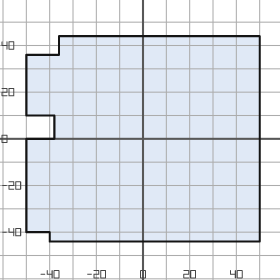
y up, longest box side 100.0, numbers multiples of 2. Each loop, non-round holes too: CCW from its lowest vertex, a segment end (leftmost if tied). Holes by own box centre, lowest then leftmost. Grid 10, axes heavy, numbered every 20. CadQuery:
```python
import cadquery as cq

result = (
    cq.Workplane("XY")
    .moveTo(-40.0, -44.0)
    .lineTo(50.0, -44.0)
    .lineTo(50.0, 44.0)
    .lineTo(-36.0, 44.0)
    .lineTo(-36.0, 36.0)
    .lineTo(-50.0, 36.0)
    .lineTo(-50.0, 10.0)
    .lineTo(-38.0, 10.0)
    .lineTo(-38.0, 0.0)
    .lineTo(-50.0, 0.0)
    .lineTo(-50.0, -40.0)
    .lineTo(-40.0, -40.0)
    .close()
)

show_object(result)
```